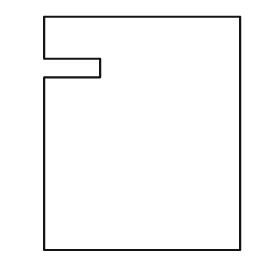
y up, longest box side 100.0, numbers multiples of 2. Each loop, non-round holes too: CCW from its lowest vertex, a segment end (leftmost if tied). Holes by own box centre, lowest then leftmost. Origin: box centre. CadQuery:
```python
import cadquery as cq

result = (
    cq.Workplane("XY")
    .moveTo(-42.0, -50.0)
    .lineTo(42.0, -50.0)
    .lineTo(42.0, 50.0)
    .lineTo(-42.0, 50.0)
    .lineTo(-42.0, 32.0)
    .lineTo(-18.0, 32.0)
    .lineTo(-18.0, 24.0)
    .lineTo(-42.0, 24.0)
    .close()
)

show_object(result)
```